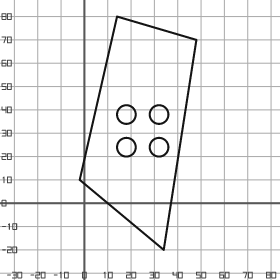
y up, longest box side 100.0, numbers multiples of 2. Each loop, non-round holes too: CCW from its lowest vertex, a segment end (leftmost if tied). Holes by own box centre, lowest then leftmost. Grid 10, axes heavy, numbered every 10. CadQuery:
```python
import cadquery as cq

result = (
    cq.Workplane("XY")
    .moveTo(34.0, -20.0)
    .lineTo(48.0, 70.0)
    .lineTo(14.0, 80.0)
    .lineTo(-2.0, 10.0)
    .close()
    .moveTo(18.0, 24.0)
    .circle(4.0)
    .moveTo(32.0, 24.0)
    .circle(4.0)
    .moveTo(18.0, 38.0)
    .circle(4.0)
    .moveTo(32.0, 38.0)
    .circle(4.0)
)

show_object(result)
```